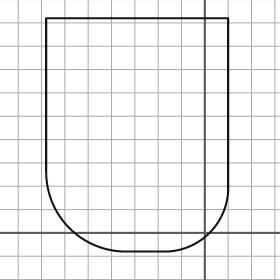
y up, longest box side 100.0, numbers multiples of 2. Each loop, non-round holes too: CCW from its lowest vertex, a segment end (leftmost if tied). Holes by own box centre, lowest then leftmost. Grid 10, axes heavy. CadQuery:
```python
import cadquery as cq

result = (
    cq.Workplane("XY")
    .moveTo(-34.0, -8.0)
    .lineTo(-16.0, -8.0)
    .threePointArc((2.0, 0.0), (10.0, 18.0))
    .lineTo(10.0, 92.0)
    .lineTo(-68.0, 92.0)
    .lineTo(-68.0, 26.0)
    .threePointArc((-58.0, 2.0), (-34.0, -8.0))
    .close()
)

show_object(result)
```